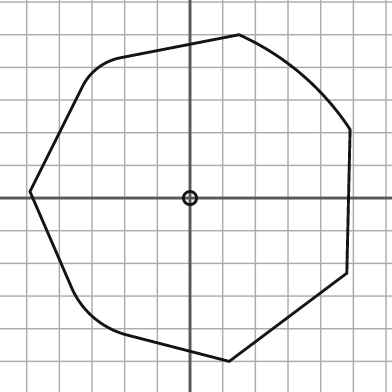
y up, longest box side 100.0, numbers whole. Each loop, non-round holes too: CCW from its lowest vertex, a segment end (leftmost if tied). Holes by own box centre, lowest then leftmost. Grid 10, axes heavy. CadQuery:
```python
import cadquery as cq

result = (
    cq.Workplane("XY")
    .moveTo(12.0, -50.0)
    .lineTo(48.0, -23.0)
    .lineTo(49.0, 21.0)
    .threePointArc((34.0, 38.0), (15.0, 50.0))
    .lineTo(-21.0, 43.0)
    .threePointArc((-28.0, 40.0), (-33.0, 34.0))
    .lineTo(-49.0, 2.0)
    .lineTo(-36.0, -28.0)
    .threePointArc((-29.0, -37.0), (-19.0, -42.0))
    .close()
    .moveTo(0.0, 0.0)
    .circle(2.0)
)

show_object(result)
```